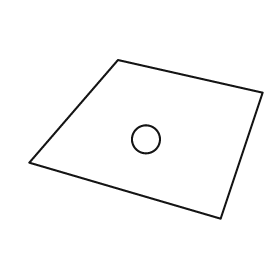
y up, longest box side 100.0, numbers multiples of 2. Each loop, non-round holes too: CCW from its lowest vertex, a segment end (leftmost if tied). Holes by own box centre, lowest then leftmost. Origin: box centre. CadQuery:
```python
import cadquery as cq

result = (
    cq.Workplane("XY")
    .moveTo(32.0, -34.0)
    .lineTo(50.0, 20.0)
    .lineTo(-12.0, 34.0)
    .lineTo(-50.0, -10.0)
    .close()
    .moveTo(0.0, 0.0)
    .circle(6.0)
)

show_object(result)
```